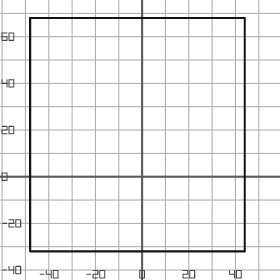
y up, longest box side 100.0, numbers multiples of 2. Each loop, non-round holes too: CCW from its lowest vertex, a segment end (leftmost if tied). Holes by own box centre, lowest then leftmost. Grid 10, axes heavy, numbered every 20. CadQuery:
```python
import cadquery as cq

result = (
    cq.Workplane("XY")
    .moveTo(-48.0, -32.0)
    .lineTo(44.0, -32.0)
    .lineTo(44.0, 68.0)
    .lineTo(-48.0, 68.0)
    .close()
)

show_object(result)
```